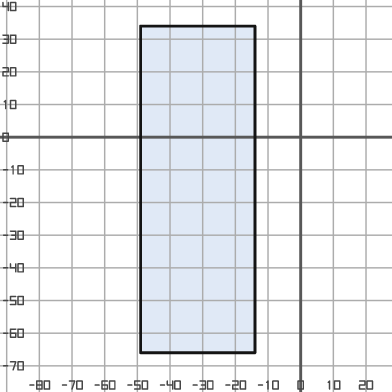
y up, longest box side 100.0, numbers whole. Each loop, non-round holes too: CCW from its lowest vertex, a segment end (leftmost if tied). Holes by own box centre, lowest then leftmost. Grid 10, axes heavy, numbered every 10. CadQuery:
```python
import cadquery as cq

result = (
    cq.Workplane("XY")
    .moveTo(-49.0, -66.0)
    .lineTo(-14.0, -66.0)
    .lineTo(-14.0, 34.0)
    .lineTo(-49.0, 34.0)
    .close()
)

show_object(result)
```